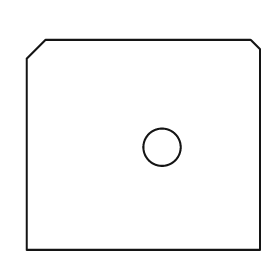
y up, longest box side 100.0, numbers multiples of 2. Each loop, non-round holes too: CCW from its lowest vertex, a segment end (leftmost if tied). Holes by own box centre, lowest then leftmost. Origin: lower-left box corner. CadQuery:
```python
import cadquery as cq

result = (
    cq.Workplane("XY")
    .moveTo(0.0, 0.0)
    .lineTo(100.0, 0.0)
    .lineTo(100.0, 86.0)
    .lineTo(96.0, 90.0)
    .lineTo(8.0, 90.0)
    .lineTo(0.0, 82.0)
    .close()
    .moveTo(58.0, 44.0)
    .circle(8.0)
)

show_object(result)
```